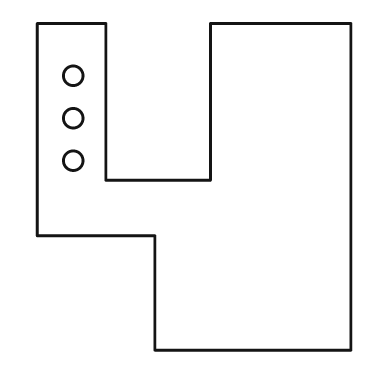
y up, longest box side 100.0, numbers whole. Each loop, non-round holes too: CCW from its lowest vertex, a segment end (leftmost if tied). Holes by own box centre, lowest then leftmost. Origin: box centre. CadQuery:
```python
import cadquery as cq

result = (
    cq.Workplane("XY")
    .moveTo(-12.0, -50.0)
    .lineTo(48.0, -50.0)
    .lineTo(48.0, 50.0)
    .lineTo(5.0, 50.0)
    .lineTo(5.0, 2.0)
    .lineTo(-27.0, 2.0)
    .lineTo(-27.0, 50.0)
    .lineTo(-48.0, 50.0)
    .lineTo(-48.0, -15.0)
    .lineTo(-12.0, -15.0)
    .close()
    .moveTo(-37.0, 8.0)
    .circle(3.0)
    .moveTo(-37.0, 21.0)
    .circle(3.0)
    .moveTo(-37.0, 34.0)
    .circle(3.0)
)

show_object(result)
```